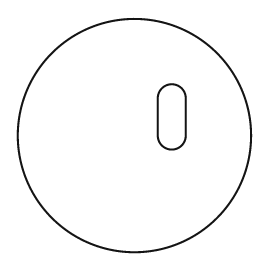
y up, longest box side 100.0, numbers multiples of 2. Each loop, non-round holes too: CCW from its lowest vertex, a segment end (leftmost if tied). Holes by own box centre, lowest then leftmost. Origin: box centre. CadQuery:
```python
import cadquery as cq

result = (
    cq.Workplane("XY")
    .moveTo(0.0, 0.0)
    .circle(50.0)
    .moveTo(10.0, 0.0)
    .threePointArc((16.0, -6.0), (22.0, 0.0))
    .lineTo(22.0, 16.0)
    .threePointArc((16.0, 22.0), (10.0, 16.0))
    .close()
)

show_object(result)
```